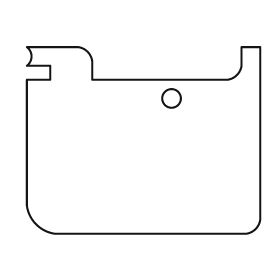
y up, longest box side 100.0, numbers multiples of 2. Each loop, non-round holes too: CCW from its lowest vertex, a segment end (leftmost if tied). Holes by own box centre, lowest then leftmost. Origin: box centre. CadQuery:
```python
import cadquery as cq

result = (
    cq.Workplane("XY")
    .moveTo(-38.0, -40.0)
    .lineTo(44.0, -40.0)
    .threePointArc((48.0, -38.0), (50.0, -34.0))
    .lineTo(50.0, 40.0)
    .lineTo(42.0, 40.0)
    .lineTo(42.0, 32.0)
    .threePointArc((40.0, 28.0), (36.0, 26.0))
    .lineTo(-22.0, 26.0)
    .lineTo(-22.0, 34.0)
    .threePointArc((-24.0, 38.0), (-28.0, 40.0))
    .lineTo(-50.0, 40.0)
    .threePointArc((-48.0, 36.0), (-50.0, 32.0))
    .lineTo(-40.0, 32.0)
    .lineTo(-40.0, 26.0)
    .lineTo(-50.0, 26.0)
    .lineTo(-50.0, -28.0)
    .threePointArc((-46.0, -36.0), (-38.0, -40.0))
    .close()
    .moveTo(12.0, 18.0)
    .circle(4.0)
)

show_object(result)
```